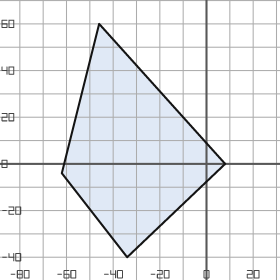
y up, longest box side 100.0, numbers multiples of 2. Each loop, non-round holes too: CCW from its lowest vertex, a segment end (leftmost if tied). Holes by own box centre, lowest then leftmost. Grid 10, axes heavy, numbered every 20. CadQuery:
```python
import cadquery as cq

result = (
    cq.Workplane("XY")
    .moveTo(-34.0, -40.0)
    .lineTo(8.0, 0.0)
    .lineTo(-46.0, 60.0)
    .lineTo(-62.0, -4.0)
    .close()
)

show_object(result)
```